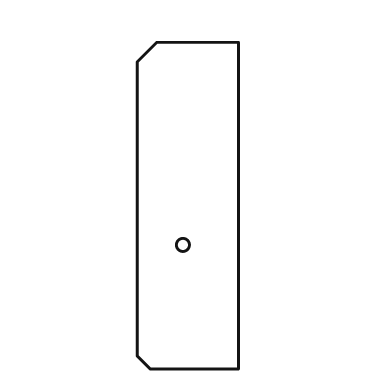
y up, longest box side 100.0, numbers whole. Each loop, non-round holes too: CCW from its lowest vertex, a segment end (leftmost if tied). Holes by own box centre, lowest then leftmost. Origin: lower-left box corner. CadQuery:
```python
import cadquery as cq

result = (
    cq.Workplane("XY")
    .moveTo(4.0, 0.0)
    .lineTo(31.0, 0.0)
    .lineTo(31.0, 100.0)
    .lineTo(6.0, 100.0)
    .lineTo(0.0, 94.0)
    .lineTo(0.0, 4.0)
    .close()
    .moveTo(14.0, 38.0)
    .circle(2.0)
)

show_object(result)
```